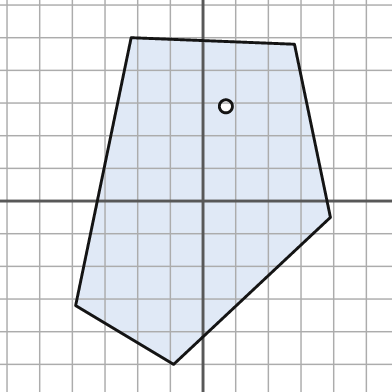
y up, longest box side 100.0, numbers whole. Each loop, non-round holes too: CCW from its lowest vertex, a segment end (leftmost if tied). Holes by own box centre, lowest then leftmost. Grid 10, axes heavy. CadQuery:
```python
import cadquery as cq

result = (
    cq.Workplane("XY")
    .moveTo(-9.0, -50.0)
    .lineTo(39.0, -5.0)
    .lineTo(28.0, 48.0)
    .lineTo(-22.0, 50.0)
    .lineTo(-39.0, -32.0)
    .close()
    .moveTo(7.0, 29.0)
    .circle(2.0)
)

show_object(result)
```